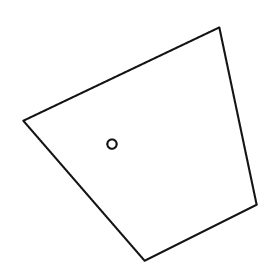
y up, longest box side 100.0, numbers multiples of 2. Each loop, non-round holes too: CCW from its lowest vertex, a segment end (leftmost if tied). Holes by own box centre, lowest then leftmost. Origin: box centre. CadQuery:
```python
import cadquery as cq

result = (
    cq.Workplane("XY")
    .moveTo(2.0, -50.0)
    .lineTo(50.0, -26.0)
    .lineTo(34.0, 50.0)
    .lineTo(-50.0, 10.0)
    .close()
    .moveTo(-12.0, 0.0)
    .circle(2.0)
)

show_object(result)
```